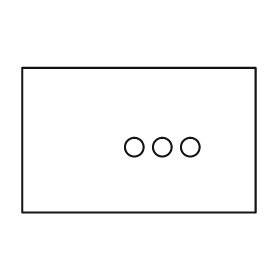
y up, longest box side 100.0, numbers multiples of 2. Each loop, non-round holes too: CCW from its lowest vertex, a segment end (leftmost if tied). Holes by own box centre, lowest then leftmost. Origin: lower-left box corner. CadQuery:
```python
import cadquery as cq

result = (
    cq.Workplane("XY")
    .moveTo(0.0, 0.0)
    .lineTo(100.0, 0.0)
    .lineTo(100.0, 62.0)
    .lineTo(0.0, 62.0)
    .close()
    .moveTo(48.0, 28.0)
    .circle(4.0)
    .moveTo(60.0, 28.0)
    .circle(4.0)
    .moveTo(72.0, 28.0)
    .circle(4.0)
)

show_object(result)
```